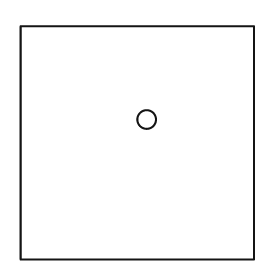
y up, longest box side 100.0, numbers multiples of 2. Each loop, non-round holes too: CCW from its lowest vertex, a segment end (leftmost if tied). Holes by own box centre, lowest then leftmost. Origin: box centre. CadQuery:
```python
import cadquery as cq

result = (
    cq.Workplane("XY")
    .moveTo(-50.0, -50.0)
    .lineTo(50.0, -50.0)
    .lineTo(50.0, 50.0)
    .lineTo(-50.0, 50.0)
    .close()
    .moveTo(4.0, 10.0)
    .circle(4.0)
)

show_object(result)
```